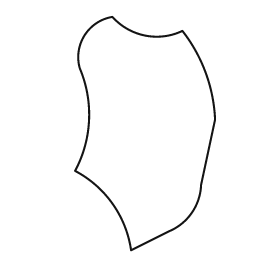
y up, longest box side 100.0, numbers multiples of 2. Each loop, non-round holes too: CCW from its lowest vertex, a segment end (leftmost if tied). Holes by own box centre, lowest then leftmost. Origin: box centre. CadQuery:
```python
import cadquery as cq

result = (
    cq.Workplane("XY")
    .moveTo(-6.0, -50.0)
    .lineTo(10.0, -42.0)
    .threePointArc((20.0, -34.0), (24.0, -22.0))
    .lineTo(30.0, 6.0)
    .threePointArc((26.0, 26.0), (16.0, 44.0))
    .threePointArc((0.0, 42.0), (-14.0, 50.0))
    .threePointArc((-26.0, 42.0), (-28.0, 28.0))
    .threePointArc((-24.0, 6.0), (-30.0, -16.0))
    .threePointArc((-14.0, -30.0), (-6.0, -50.0))
    .close()
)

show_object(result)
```